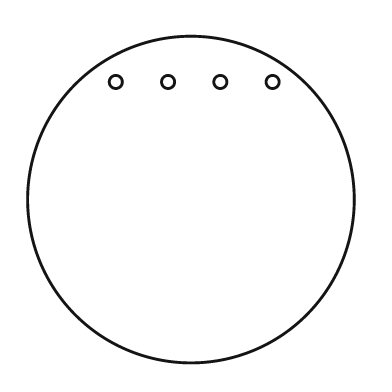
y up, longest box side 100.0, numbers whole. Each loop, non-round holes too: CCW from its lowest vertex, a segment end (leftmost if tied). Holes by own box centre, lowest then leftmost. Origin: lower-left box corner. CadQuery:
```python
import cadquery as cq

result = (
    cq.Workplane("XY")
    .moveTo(50.0, 50.0)
    .circle(50.0)
    .moveTo(27.0, 86.0)
    .circle(2.0)
    .moveTo(43.0, 86.0)
    .circle(2.0)
    .moveTo(59.0, 86.0)
    .circle(2.0)
    .moveTo(75.0, 86.0)
    .circle(2.0)
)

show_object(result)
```